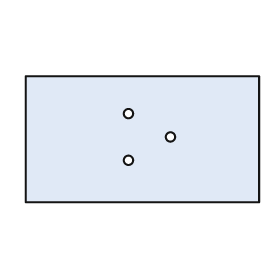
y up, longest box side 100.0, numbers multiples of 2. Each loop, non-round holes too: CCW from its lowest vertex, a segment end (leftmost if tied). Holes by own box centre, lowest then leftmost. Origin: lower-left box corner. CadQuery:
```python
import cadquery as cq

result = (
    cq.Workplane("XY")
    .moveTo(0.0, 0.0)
    .lineTo(100.0, 0.0)
    .lineTo(100.0, 54.0)
    .lineTo(0.0, 54.0)
    .close()
    .moveTo(44.0, 18.0)
    .circle(2.0)
    .moveTo(62.0, 28.0)
    .circle(2.0)
    .moveTo(44.0, 38.0)
    .circle(2.0)
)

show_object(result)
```